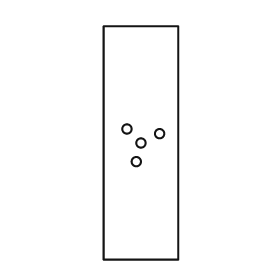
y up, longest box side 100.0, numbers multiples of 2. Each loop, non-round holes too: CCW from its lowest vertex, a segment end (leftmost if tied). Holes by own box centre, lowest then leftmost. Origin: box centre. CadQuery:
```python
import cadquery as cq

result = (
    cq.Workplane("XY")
    .moveTo(-16.0, -50.0)
    .lineTo(16.0, -50.0)
    .lineTo(16.0, 50.0)
    .lineTo(-16.0, 50.0)
    .close()
    .moveTo(-2.0, -8.0)
    .circle(2.0)
    .moveTo(0.0, 0.0)
    .circle(2.0)
    .moveTo(8.0, 4.0)
    .circle(2.0)
    .moveTo(-6.0, 6.0)
    .circle(2.0)
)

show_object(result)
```